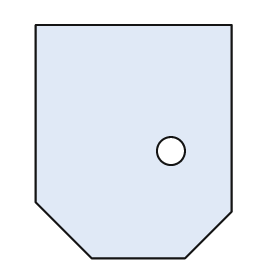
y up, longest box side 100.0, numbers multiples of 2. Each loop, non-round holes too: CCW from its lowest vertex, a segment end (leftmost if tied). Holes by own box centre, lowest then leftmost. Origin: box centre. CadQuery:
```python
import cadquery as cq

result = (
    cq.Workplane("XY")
    .moveTo(-18.0, -50.0)
    .lineTo(22.0, -50.0)
    .lineTo(42.0, -30.0)
    .lineTo(42.0, 50.0)
    .lineTo(-42.0, 50.0)
    .lineTo(-42.0, -26.0)
    .close()
    .moveTo(16.0, -4.0)
    .circle(6.0)
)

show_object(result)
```